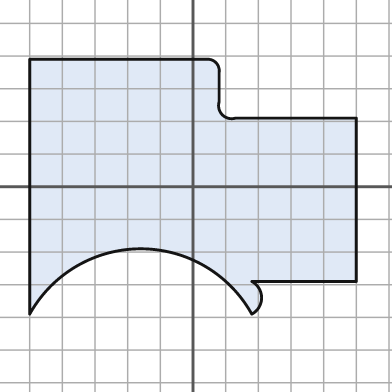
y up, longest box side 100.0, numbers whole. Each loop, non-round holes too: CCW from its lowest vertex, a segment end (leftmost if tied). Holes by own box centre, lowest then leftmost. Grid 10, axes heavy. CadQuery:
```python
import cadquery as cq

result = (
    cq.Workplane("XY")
    .moveTo(-50.0, -39.0)
    .threePointArc((-16.0, -19.0), (18.0, -39.0))
    .threePointArc((21.0, -34.0), (18.0, -29.0))
    .lineTo(50.0, -29.0)
    .lineTo(50.0, 21.0)
    .lineTo(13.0, 21.0)
    .threePointArc((9.0, 22.0), (8.0, 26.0))
    .lineTo(8.0, 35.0)
    .threePointArc((7.0, 38.0), (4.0, 39.0))
    .lineTo(-50.0, 39.0)
    .close()
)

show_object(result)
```